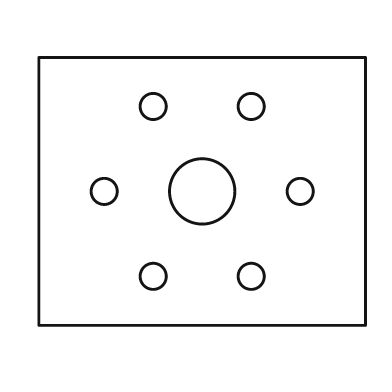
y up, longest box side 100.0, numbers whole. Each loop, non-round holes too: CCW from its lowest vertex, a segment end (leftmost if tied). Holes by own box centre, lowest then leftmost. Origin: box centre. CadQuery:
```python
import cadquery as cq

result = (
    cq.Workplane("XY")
    .moveTo(-50.0, -41.0)
    .lineTo(50.0, -41.0)
    .lineTo(50.0, 41.0)
    .lineTo(-50.0, 41.0)
    .close()
    .moveTo(-15.0, -26.0)
    .circle(4.0)
    .moveTo(15.0, -26.0)
    .circle(4.0)
    .moveTo(-30.0, 0.0)
    .circle(4.0)
    .moveTo(0.0, 0.0)
    .circle(10.0)
    .moveTo(30.0, 0.0)
    .circle(4.0)
    .moveTo(-15.0, 26.0)
    .circle(4.0)
    .moveTo(15.0, 26.0)
    .circle(4.0)
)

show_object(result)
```